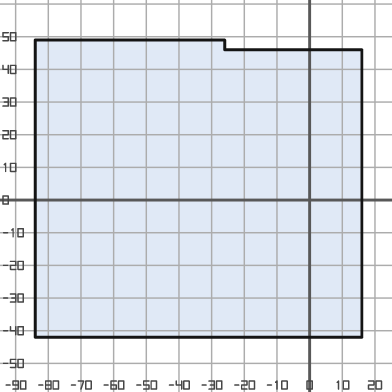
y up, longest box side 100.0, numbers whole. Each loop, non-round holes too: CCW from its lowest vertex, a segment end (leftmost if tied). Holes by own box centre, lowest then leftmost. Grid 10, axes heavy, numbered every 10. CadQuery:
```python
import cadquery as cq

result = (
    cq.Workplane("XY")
    .moveTo(-84.0, -42.0)
    .lineTo(16.0, -42.0)
    .lineTo(16.0, 46.0)
    .lineTo(-26.0, 46.0)
    .lineTo(-26.0, 49.0)
    .lineTo(-84.0, 49.0)
    .close()
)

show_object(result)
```